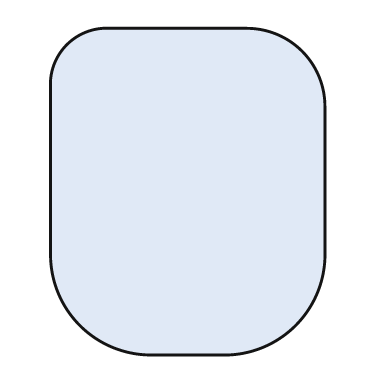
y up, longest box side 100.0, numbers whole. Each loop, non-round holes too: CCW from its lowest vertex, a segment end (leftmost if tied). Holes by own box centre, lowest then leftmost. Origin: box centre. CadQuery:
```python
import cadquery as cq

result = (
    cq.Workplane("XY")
    .moveTo(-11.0, -50.0)
    .lineTo(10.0, -50.0)
    .threePointArc((33.0, -41.0), (42.0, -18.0))
    .lineTo(42.0, 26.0)
    .threePointArc((35.0, 43.0), (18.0, 50.0))
    .lineTo(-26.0, 50.0)
    .threePointArc((-37.0, 45.0), (-42.0, 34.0))
    .lineTo(-42.0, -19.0)
    .threePointArc((-33.0, -41.0), (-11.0, -50.0))
    .close()
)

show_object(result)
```